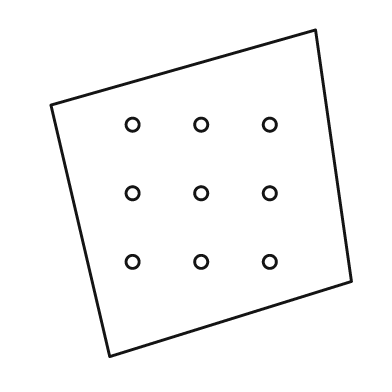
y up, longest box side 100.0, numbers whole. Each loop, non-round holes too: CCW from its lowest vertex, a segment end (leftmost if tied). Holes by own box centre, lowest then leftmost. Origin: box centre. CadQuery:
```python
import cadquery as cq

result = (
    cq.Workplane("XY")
    .moveTo(-28.0, -50.0)
    .lineTo(46.0, -27.0)
    .lineTo(35.0, 50.0)
    .lineTo(-46.0, 27.0)
    .close()
    .moveTo(-21.0, -21.0)
    .circle(2.0)
    .moveTo(0.0, -21.0)
    .circle(2.0)
    .moveTo(21.0, -21.0)
    .circle(2.0)
    .moveTo(-21.0, 0.0)
    .circle(2.0)
    .moveTo(0.0, 0.0)
    .circle(2.0)
    .moveTo(21.0, 0.0)
    .circle(2.0)
    .moveTo(-21.0, 21.0)
    .circle(2.0)
    .moveTo(0.0, 21.0)
    .circle(2.0)
    .moveTo(21.0, 21.0)
    .circle(2.0)
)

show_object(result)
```